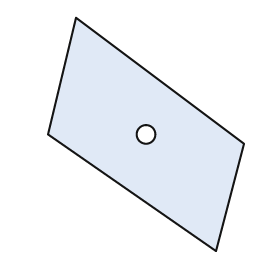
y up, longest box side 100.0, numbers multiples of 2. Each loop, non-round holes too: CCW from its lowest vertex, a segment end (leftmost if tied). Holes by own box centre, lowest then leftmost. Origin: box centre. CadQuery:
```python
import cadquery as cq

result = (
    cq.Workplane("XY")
    .moveTo(30.0, -50.0)
    .lineTo(42.0, -4.0)
    .lineTo(-30.0, 50.0)
    .lineTo(-42.0, 0.0)
    .close()
    .moveTo(0.0, 0.0)
    .circle(4.0)
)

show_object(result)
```